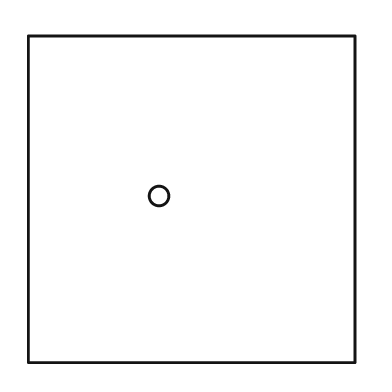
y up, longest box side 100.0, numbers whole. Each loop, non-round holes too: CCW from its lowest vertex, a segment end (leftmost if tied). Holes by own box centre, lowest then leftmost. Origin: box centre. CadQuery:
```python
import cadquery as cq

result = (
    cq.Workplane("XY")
    .moveTo(-50.0, -50.0)
    .lineTo(50.0, -50.0)
    .lineTo(50.0, 50.0)
    .lineTo(-50.0, 50.0)
    .close()
    .moveTo(-10.0, 1.0)
    .circle(3.0)
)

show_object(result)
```